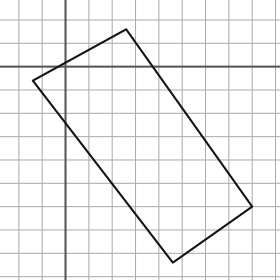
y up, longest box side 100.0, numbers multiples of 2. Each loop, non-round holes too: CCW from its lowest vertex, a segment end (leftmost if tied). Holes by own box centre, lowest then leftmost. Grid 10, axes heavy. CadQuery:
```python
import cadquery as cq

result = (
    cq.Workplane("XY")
    .moveTo(46.0, -84.0)
    .lineTo(80.0, -60.0)
    .lineTo(26.0, 16.0)
    .lineTo(-14.0, -6.0)
    .close()
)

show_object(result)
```